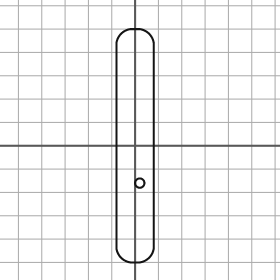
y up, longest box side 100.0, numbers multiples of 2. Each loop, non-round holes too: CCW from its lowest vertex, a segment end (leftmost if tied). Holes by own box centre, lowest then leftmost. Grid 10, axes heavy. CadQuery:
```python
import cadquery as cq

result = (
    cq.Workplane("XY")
    .moveTo(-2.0, -50.0)
    .lineTo(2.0, -50.0)
    .threePointArc((6.0, -48.0), (8.0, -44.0))
    .lineTo(8.0, 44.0)
    .threePointArc((6.0, 48.0), (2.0, 50.0))
    .lineTo(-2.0, 50.0)
    .threePointArc((-6.0, 48.0), (-8.0, 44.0))
    .lineTo(-8.0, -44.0)
    .threePointArc((-6.0, -48.0), (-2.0, -50.0))
    .close()
    .moveTo(2.0, -16.0)
    .circle(2.0)
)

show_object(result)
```